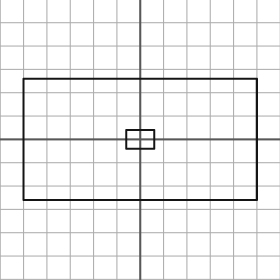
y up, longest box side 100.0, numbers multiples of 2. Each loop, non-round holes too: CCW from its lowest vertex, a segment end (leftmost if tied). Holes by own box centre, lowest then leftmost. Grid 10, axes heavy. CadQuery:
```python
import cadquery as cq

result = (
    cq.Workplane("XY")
    .moveTo(-50.0, -26.0)
    .lineTo(50.0, -26.0)
    .lineTo(50.0, 26.0)
    .lineTo(-50.0, 26.0)
    .close()
    .moveTo(-6.0, -4.0)
    .lineTo(6.0, -4.0)
    .lineTo(6.0, 4.0)
    .lineTo(-6.0, 4.0)
    .close()
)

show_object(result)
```